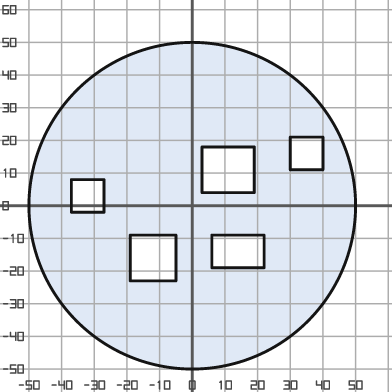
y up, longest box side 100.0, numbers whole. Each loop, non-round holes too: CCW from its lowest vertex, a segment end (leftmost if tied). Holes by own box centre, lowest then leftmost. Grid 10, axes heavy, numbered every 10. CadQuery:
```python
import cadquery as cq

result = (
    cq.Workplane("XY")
    .moveTo(0.0, 0.0)
    .circle(50.0)
    .moveTo(-19.0, -23.0)
    .lineTo(-5.0, -23.0)
    .lineTo(-5.0, -9.0)
    .lineTo(-19.0, -9.0)
    .close()
    .moveTo(6.0, -19.0)
    .lineTo(22.0, -19.0)
    .lineTo(22.0, -9.0)
    .lineTo(6.0, -9.0)
    .close()
    .moveTo(-37.0, -2.0)
    .lineTo(-27.0, -2.0)
    .lineTo(-27.0, 8.0)
    .lineTo(-37.0, 8.0)
    .close()
    .moveTo(3.0, 4.0)
    .lineTo(19.0, 4.0)
    .lineTo(19.0, 18.0)
    .lineTo(3.0, 18.0)
    .close()
    .moveTo(30.0, 11.0)
    .lineTo(40.0, 11.0)
    .lineTo(40.0, 21.0)
    .lineTo(30.0, 21.0)
    .close()
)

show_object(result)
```